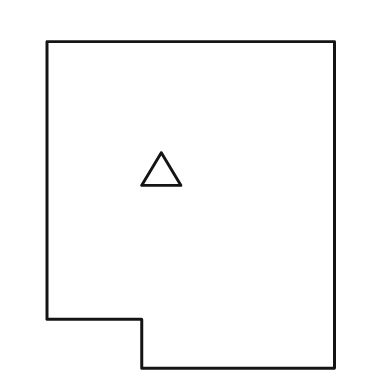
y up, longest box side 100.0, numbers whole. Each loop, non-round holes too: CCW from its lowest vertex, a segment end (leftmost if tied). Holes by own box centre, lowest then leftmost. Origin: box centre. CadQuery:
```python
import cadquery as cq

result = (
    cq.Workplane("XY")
    .moveTo(-15.0, -50.0)
    .lineTo(44.0, -50.0)
    .lineTo(44.0, 50.0)
    .lineTo(-44.0, 50.0)
    .lineTo(-44.0, -35.0)
    .lineTo(-15.0, -35.0)
    .close()
    .moveTo(-15.0, 6.0)
    .lineTo(-3.0, 6.0)
    .lineTo(-9.0, 16.0)
    .close()
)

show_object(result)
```